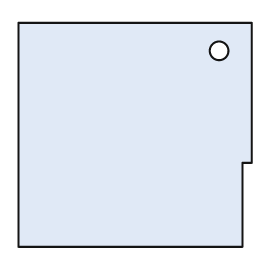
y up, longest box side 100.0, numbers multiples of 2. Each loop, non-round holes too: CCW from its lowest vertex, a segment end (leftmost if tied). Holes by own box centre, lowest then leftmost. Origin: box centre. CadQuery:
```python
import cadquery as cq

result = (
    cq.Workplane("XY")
    .moveTo(-50.0, -48.0)
    .lineTo(46.0, -48.0)
    .lineTo(46.0, -12.0)
    .lineTo(50.0, -12.0)
    .lineTo(50.0, 48.0)
    .lineTo(-50.0, 48.0)
    .close()
    .moveTo(36.0, 36.0)
    .circle(4.0)
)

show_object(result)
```